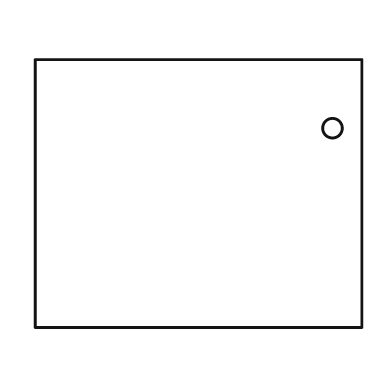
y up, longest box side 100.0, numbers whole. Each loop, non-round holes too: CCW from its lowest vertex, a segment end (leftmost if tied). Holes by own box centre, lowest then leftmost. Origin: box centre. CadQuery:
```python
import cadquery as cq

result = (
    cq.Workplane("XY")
    .moveTo(-50.0, -41.0)
    .lineTo(50.0, -41.0)
    .lineTo(50.0, 41.0)
    .lineTo(-50.0, 41.0)
    .close()
    .moveTo(41.0, 20.0)
    .circle(3.0)
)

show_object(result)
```